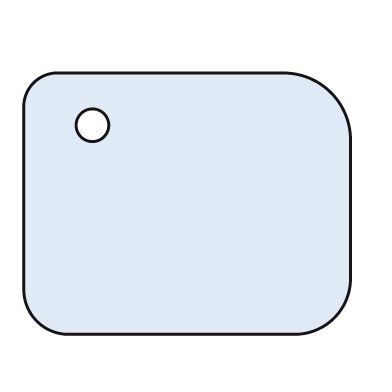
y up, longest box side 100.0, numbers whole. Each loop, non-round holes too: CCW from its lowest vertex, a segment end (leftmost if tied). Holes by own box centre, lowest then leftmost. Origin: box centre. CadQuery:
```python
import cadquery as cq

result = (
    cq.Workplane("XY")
    .moveTo(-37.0, -40.0)
    .lineTo(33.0, -40.0)
    .threePointArc((45.0, -35.0), (50.0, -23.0))
    .lineTo(50.0, 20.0)
    .threePointArc((44.0, 34.0), (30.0, 40.0))
    .lineTo(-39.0, 40.0)
    .threePointArc((-47.0, 37.0), (-50.0, 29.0))
    .lineTo(-50.0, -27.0)
    .threePointArc((-46.0, -36.0), (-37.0, -40.0))
    .close()
    .moveTo(-29.0, 24.0)
    .circle(5.0)
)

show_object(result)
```